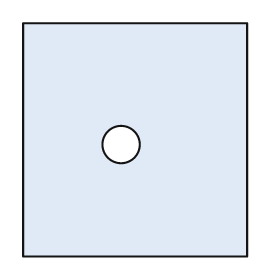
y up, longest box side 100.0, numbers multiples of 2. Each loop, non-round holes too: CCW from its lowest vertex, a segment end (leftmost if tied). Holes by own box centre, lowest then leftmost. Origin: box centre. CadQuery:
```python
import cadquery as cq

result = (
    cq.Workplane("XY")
    .moveTo(-48.0, -50.0)
    .lineTo(48.0, -50.0)
    .lineTo(48.0, 50.0)
    .lineTo(-48.0, 50.0)
    .close()
    .moveTo(-6.0, -2.0)
    .circle(8.0)
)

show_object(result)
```